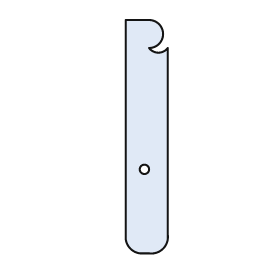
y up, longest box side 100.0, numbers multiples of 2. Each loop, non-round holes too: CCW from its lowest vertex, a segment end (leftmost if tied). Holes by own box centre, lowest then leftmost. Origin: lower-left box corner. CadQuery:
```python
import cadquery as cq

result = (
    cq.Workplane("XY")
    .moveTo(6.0, 0.0)
    .lineTo(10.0, 0.0)
    .threePointArc((16.0, 2.0), (18.0, 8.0))
    .lineTo(18.0, 88.0)
    .threePointArc((14.0, 86.0), (10.0, 88.0))
    .threePointArc((16.0, 94.0), (10.0, 100.0))
    .lineTo(0.0, 100.0)
    .lineTo(0.0, 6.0)
    .threePointArc((2.0, 2.0), (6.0, 0.0))
    .close()
    .moveTo(8.0, 36.0)
    .circle(2.0)
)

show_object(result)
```